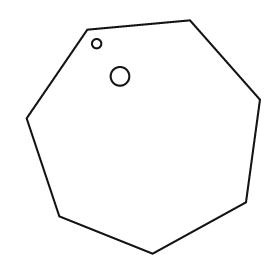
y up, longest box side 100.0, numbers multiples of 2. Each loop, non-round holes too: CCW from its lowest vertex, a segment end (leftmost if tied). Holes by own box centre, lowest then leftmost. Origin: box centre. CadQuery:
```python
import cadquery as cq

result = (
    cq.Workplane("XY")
    .moveTo(4.0, -50.0)
    .lineTo(44.0, -28.0)
    .lineTo(50.0, 16.0)
    .lineTo(20.0, 50.0)
    .lineTo(-24.0, 46.0)
    .lineTo(-50.0, 8.0)
    .lineTo(-36.0, -34.0)
    .close()
    .moveTo(-10.0, 26.0)
    .circle(4.0)
    .moveTo(-20.0, 40.0)
    .circle(2.0)
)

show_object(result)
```